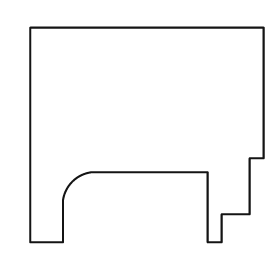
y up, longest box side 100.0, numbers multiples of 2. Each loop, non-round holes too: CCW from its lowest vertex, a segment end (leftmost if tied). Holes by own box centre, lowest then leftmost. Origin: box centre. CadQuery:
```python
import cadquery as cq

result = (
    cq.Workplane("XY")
    .moveTo(-50.0, -46.0)
    .lineTo(-36.0, -46.0)
    .lineTo(-36.0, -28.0)
    .threePointArc((-32.0, -20.0), (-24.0, -16.0))
    .lineTo(26.0, -16.0)
    .lineTo(26.0, -46.0)
    .lineTo(32.0, -46.0)
    .lineTo(32.0, -34.0)
    .lineTo(44.0, -34.0)
    .lineTo(44.0, -10.0)
    .lineTo(50.0, -10.0)
    .lineTo(50.0, 46.0)
    .lineTo(-50.0, 46.0)
    .close()
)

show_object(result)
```